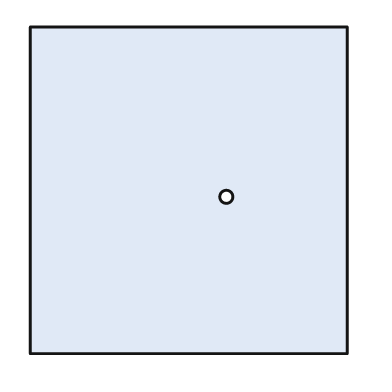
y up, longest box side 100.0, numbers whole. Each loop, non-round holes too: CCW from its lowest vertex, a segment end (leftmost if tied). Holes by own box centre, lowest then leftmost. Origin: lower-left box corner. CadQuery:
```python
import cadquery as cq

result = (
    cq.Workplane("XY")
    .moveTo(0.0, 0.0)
    .lineTo(97.0, 0.0)
    .lineTo(97.0, 100.0)
    .lineTo(0.0, 100.0)
    .close()
    .moveTo(60.0, 48.0)
    .circle(2.0)
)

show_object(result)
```